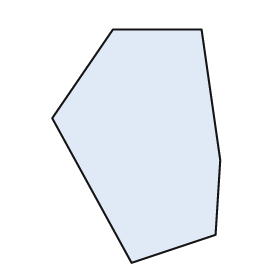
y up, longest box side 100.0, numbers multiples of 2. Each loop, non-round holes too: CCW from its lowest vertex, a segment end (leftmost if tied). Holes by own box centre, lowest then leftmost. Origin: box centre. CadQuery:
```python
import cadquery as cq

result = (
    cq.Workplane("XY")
    .moveTo(-2.0, -50.0)
    .lineTo(34.0, -38.0)
    .lineTo(36.0, -6.0)
    .lineTo(28.0, 50.0)
    .lineTo(-10.0, 50.0)
    .lineTo(-36.0, 12.0)
    .close()
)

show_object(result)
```